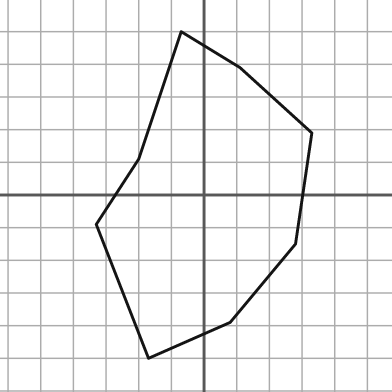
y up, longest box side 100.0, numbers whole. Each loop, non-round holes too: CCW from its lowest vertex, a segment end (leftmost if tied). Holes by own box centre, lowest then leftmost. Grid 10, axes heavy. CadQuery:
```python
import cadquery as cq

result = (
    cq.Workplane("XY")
    .moveTo(-17.0, -50.0)
    .lineTo(8.0, -39.0)
    .lineTo(28.0, -15.0)
    .lineTo(33.0, 19.0)
    .lineTo(11.0, 39.0)
    .lineTo(-7.0, 50.0)
    .lineTo(-20.0, 11.0)
    .lineTo(-33.0, -9.0)
    .close()
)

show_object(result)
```